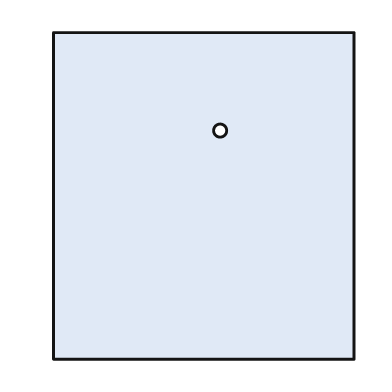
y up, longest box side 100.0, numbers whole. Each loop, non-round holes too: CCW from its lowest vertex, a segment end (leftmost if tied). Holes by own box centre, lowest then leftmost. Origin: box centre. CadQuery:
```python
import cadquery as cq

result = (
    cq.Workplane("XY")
    .moveTo(-46.0, -50.0)
    .lineTo(46.0, -50.0)
    .lineTo(46.0, 50.0)
    .lineTo(-46.0, 50.0)
    .close()
    .moveTo(5.0, 20.0)
    .circle(2.0)
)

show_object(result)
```